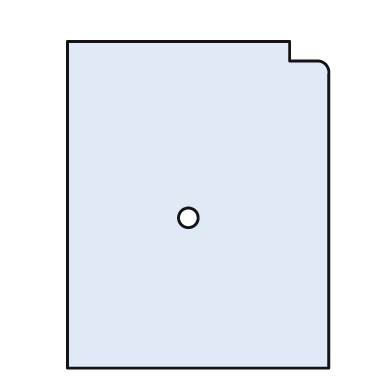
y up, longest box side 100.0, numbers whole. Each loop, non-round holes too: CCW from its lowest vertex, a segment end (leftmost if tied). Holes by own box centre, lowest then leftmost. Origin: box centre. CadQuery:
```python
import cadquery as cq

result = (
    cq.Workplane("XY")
    .moveTo(-40.0, -50.0)
    .lineTo(40.0, -50.0)
    .lineTo(40.0, 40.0)
    .threePointArc((39.0, 43.0), (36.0, 44.0))
    .lineTo(28.0, 44.0)
    .lineTo(28.0, 50.0)
    .lineTo(-40.0, 50.0)
    .close()
    .moveTo(-3.0, -4.0)
    .circle(3.0)
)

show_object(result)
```